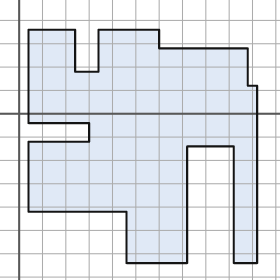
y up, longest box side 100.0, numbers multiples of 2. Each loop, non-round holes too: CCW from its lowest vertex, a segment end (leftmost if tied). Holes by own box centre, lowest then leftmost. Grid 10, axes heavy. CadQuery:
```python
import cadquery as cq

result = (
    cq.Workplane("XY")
    .moveTo(46.0, -64.0)
    .lineTo(72.0, -64.0)
    .lineTo(72.0, -14.0)
    .lineTo(92.0, -14.0)
    .lineTo(92.0, -64.0)
    .lineTo(102.0, -64.0)
    .lineTo(102.0, 12.0)
    .lineTo(98.0, 12.0)
    .lineTo(98.0, 28.0)
    .lineTo(60.0, 28.0)
    .lineTo(60.0, 36.0)
    .lineTo(34.0, 36.0)
    .lineTo(34.0, 18.0)
    .lineTo(24.0, 18.0)
    .lineTo(24.0, 36.0)
    .lineTo(4.0, 36.0)
    .lineTo(4.0, -4.0)
    .lineTo(30.0, -4.0)
    .lineTo(30.0, -12.0)
    .lineTo(4.0, -12.0)
    .lineTo(4.0, -42.0)
    .lineTo(46.0, -42.0)
    .close()
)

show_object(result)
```